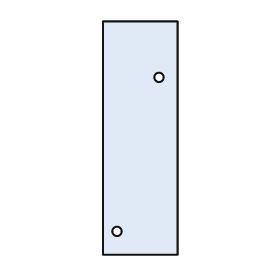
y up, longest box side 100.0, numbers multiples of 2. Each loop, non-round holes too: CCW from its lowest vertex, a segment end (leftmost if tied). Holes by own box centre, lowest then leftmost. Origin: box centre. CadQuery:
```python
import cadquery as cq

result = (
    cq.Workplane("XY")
    .moveTo(-16.0, -50.0)
    .lineTo(16.0, -50.0)
    .lineTo(16.0, 50.0)
    .lineTo(-16.0, 50.0)
    .close()
    .moveTo(-10.0, -40.0)
    .circle(2.0)
    .moveTo(8.0, 26.0)
    .circle(2.0)
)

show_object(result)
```